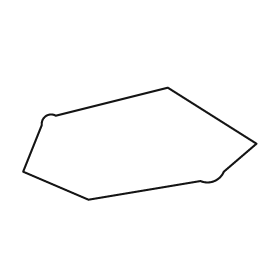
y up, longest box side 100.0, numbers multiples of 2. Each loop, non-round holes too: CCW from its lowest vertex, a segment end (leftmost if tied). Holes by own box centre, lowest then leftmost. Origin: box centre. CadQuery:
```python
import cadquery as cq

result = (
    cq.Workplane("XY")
    .moveTo(-22.0, -24.0)
    .lineTo(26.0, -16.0)
    .threePointArc((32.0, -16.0), (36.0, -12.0))
    .lineTo(50.0, 0.0)
    .lineTo(12.0, 24.0)
    .lineTo(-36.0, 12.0)
    .threePointArc((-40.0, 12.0), (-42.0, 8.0))
    .lineTo(-50.0, -12.0)
    .close()
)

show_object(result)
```